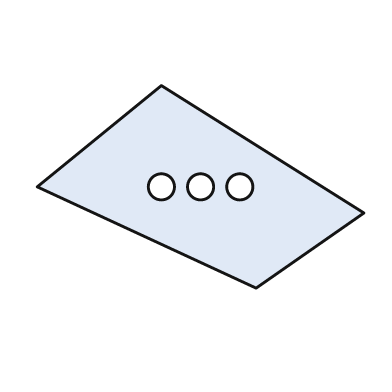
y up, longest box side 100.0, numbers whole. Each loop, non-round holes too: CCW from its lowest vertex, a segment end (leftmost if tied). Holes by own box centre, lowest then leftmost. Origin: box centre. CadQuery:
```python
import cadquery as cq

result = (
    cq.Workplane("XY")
    .moveTo(17.0, -31.0)
    .lineTo(50.0, -8.0)
    .lineTo(-12.0, 31.0)
    .lineTo(-50.0, 0.0)
    .close()
    .moveTo(-12.0, 0.0)
    .circle(4.0)
    .moveTo(0.0, 0.0)
    .circle(4.0)
    .moveTo(12.0, 0.0)
    .circle(4.0)
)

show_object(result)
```